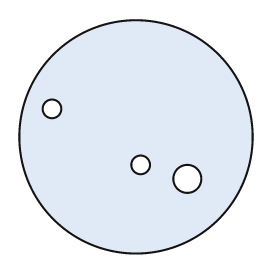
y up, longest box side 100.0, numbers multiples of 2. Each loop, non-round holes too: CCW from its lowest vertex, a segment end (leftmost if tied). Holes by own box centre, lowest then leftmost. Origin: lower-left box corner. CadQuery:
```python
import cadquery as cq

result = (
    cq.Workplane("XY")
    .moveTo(50.0, 50.0)
    .circle(50.0)
    .moveTo(72.0, 32.0)
    .circle(6.0)
    .moveTo(52.0, 38.0)
    .circle(4.0)
    .moveTo(14.0, 62.0)
    .circle(4.0)
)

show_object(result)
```